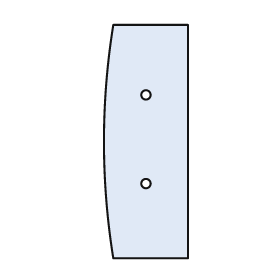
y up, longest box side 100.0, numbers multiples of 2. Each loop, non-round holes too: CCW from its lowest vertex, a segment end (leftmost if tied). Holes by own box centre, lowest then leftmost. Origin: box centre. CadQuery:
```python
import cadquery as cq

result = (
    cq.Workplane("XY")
    .moveTo(-14.0, -50.0)
    .lineTo(18.0, -50.0)
    .lineTo(18.0, 50.0)
    .lineTo(-14.0, 50.0)
    .threePointArc((-18.0, 0.0), (-14.0, -50.0))
    .close()
    .moveTo(0.0, -18.0)
    .circle(2.0)
    .moveTo(0.0, 20.0)
    .circle(2.0)
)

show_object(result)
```